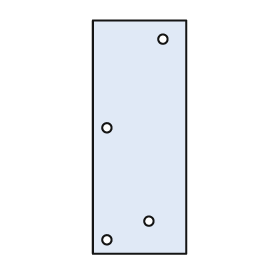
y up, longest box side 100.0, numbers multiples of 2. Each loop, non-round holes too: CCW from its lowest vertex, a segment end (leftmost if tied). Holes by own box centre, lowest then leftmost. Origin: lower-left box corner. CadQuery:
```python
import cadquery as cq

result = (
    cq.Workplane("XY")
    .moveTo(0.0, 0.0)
    .lineTo(40.0, 0.0)
    .lineTo(40.0, 100.0)
    .lineTo(0.0, 100.0)
    .close()
    .moveTo(6.0, 6.0)
    .circle(2.0)
    .moveTo(24.0, 14.0)
    .circle(2.0)
    .moveTo(6.0, 54.0)
    .circle(2.0)
    .moveTo(30.0, 92.0)
    .circle(2.0)
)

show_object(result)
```